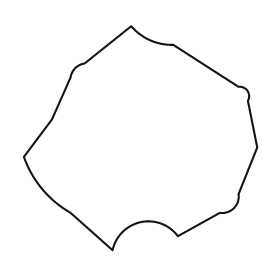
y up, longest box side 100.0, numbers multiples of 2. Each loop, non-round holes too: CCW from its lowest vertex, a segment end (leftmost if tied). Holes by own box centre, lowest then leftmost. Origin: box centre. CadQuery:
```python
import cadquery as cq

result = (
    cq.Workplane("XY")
    .moveTo(-12.0, -48.0)
    .threePointArc((0.0, -36.0), (16.0, -42.0))
    .lineTo(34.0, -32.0)
    .threePointArc((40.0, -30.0), (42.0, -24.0))
    .lineTo(50.0, -4.0)
    .lineTo(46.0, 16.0)
    .threePointArc((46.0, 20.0), (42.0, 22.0))
    .lineTo(14.0, 40.0)
    .threePointArc((4.0, 42.0), (-4.0, 48.0))
    .lineTo(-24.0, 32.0)
    .threePointArc((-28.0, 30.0), (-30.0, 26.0))
    .lineTo(-38.0, 8.0)
    .lineTo(-50.0, -8.0)
    .threePointArc((-42.0, -22.0), (-30.0, -32.0))
    .close()
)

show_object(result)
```